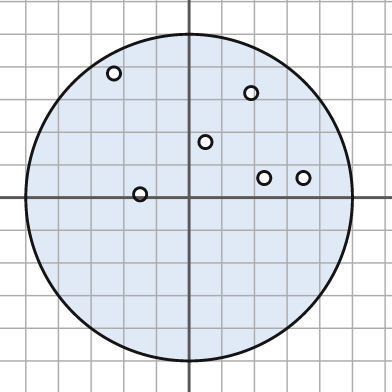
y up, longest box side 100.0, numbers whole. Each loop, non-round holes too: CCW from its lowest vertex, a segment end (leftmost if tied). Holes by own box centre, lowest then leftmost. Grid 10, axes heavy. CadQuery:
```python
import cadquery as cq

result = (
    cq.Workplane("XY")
    .moveTo(0.0, 0.0)
    .circle(50.0)
    .moveTo(-15.0, 1.0)
    .circle(2.0)
    .moveTo(23.0, 6.0)
    .circle(2.0)
    .moveTo(35.0, 6.0)
    .circle(2.0)
    .moveTo(5.0, 17.0)
    .circle(2.0)
    .moveTo(19.0, 32.0)
    .circle(2.0)
    .moveTo(-23.0, 38.0)
    .circle(2.0)
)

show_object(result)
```